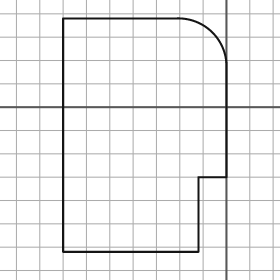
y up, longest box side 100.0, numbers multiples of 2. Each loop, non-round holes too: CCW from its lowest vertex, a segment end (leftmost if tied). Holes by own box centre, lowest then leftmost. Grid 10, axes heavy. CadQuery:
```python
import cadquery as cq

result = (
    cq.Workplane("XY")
    .moveTo(-70.0, -62.0)
    .lineTo(-12.0, -62.0)
    .lineTo(-12.0, -30.0)
    .lineTo(0.0, -30.0)
    .lineTo(0.0, 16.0)
    .threePointArc((-6.0, 32.0), (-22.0, 38.0))
    .lineTo(-70.0, 38.0)
    .close()
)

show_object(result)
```